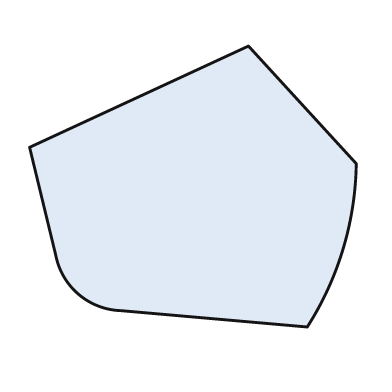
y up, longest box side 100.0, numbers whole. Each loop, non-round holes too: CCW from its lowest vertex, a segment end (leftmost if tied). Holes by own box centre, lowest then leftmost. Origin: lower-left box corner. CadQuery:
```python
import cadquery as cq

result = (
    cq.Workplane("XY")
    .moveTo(85.0, 0.0)
    .threePointArc((96.0, 24.0), (100.0, 50.0))
    .lineTo(67.0, 86.0)
    .lineTo(0.0, 55.0)
    .lineTo(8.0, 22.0)
    .threePointArc((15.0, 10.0), (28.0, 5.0))
    .close()
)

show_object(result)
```